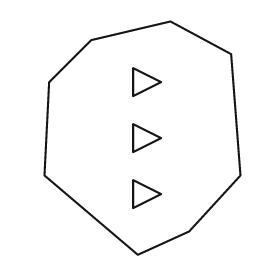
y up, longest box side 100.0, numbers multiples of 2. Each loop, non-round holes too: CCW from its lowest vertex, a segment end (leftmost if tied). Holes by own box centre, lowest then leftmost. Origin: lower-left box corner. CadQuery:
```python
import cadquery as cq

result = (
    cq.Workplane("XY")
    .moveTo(40.0, 0.0)
    .lineTo(62.0, 10.0)
    .lineTo(84.0, 34.0)
    .lineTo(80.0, 86.0)
    .lineTo(54.0, 100.0)
    .lineTo(20.0, 92.0)
    .lineTo(2.0, 74.0)
    .lineTo(0.0, 34.0)
    .close()
    .moveTo(38.0, 20.0)
    .lineTo(50.0, 26.0)
    .lineTo(38.0, 32.0)
    .close()
    .moveTo(38.0, 44.0)
    .lineTo(50.0, 50.0)
    .lineTo(38.0, 56.0)
    .close()
    .moveTo(38.0, 68.0)
    .lineTo(50.0, 74.0)
    .lineTo(38.0, 80.0)
    .close()
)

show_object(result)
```